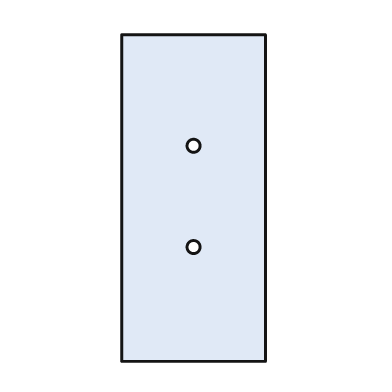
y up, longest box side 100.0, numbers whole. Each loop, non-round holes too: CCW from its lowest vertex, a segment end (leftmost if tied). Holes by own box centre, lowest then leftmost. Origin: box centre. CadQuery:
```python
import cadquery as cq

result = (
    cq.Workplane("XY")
    .moveTo(-22.0, -50.0)
    .lineTo(22.0, -50.0)
    .lineTo(22.0, 50.0)
    .lineTo(-22.0, 50.0)
    .close()
    .moveTo(0.0, -15.0)
    .circle(2.0)
    .moveTo(0.0, 16.0)
    .circle(2.0)
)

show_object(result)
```